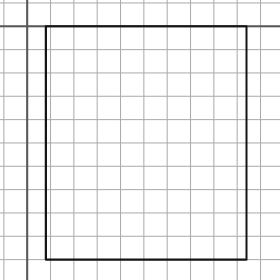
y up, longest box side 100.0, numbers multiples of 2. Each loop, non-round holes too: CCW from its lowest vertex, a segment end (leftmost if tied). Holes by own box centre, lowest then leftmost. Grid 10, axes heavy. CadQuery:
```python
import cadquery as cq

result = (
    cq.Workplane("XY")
    .moveTo(8.0, -100.0)
    .lineTo(94.0, -100.0)
    .lineTo(94.0, 0.0)
    .lineTo(8.0, 0.0)
    .close()
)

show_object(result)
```